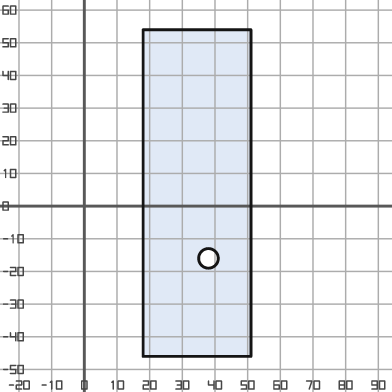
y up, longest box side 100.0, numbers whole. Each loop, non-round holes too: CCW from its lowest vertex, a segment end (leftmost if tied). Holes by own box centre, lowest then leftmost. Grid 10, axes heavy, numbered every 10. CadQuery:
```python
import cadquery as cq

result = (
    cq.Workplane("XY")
    .moveTo(18.0, -46.0)
    .lineTo(51.0, -46.0)
    .lineTo(51.0, 54.0)
    .lineTo(18.0, 54.0)
    .close()
    .moveTo(38.0, -16.0)
    .circle(3.0)
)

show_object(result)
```